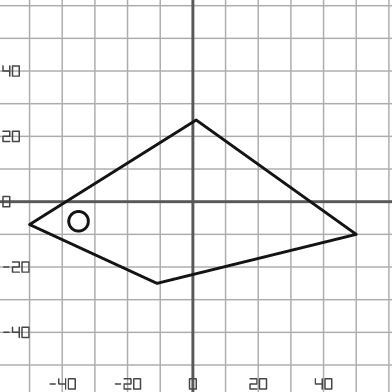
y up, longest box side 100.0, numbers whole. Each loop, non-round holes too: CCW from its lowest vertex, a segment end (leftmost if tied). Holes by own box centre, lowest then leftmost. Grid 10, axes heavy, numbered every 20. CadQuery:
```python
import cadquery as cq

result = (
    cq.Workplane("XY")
    .moveTo(-11.0, -25.0)
    .lineTo(50.0, -10.0)
    .lineTo(1.0, 25.0)
    .lineTo(-50.0, -7.0)
    .close()
    .moveTo(-35.0, -6.0)
    .circle(3.0)
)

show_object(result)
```